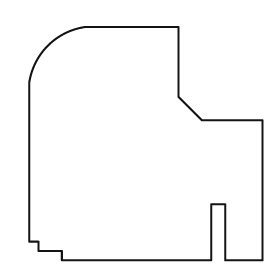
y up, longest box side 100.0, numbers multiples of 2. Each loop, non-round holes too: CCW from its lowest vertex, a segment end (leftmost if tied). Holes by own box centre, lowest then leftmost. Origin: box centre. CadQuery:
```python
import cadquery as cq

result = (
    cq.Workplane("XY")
    .moveTo(-36.0, -50.0)
    .lineTo(28.0, -50.0)
    .lineTo(28.0, -26.0)
    .lineTo(34.0, -26.0)
    .lineTo(34.0, -50.0)
    .lineTo(50.0, -50.0)
    .lineTo(50.0, 10.0)
    .lineTo(24.0, 10.0)
    .lineTo(14.0, 20.0)
    .lineTo(14.0, 50.0)
    .lineTo(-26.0, 50.0)
    .threePointArc((-42.0, 42.0), (-50.0, 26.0))
    .lineTo(-50.0, -42.0)
    .lineTo(-46.0, -42.0)
    .lineTo(-46.0, -46.0)
    .lineTo(-36.0, -46.0)
    .close()
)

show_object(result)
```